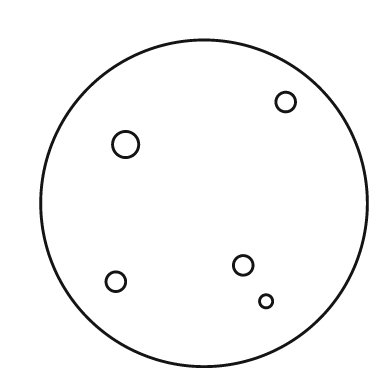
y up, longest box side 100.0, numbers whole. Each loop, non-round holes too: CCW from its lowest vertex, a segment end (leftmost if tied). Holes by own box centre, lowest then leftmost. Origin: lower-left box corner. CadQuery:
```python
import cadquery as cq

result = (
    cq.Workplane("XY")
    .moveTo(50.0, 50.0)
    .circle(50.0)
    .moveTo(69.0, 20.0)
    .circle(2.0)
    .moveTo(23.0, 26.0)
    .circle(3.0)
    .moveTo(62.0, 31.0)
    .circle(3.0)
    .moveTo(26.0, 68.0)
    .circle(4.0)
    .moveTo(75.0, 81.0)
    .circle(3.0)
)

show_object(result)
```